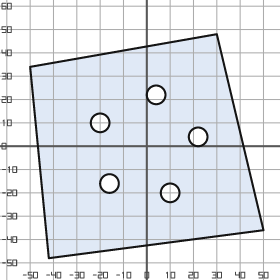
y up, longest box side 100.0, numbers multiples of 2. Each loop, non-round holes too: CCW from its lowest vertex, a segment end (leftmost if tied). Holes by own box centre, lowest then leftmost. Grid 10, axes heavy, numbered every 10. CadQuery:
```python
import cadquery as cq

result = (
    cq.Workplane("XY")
    .moveTo(-42.0, -48.0)
    .lineTo(50.0, -36.0)
    .lineTo(30.0, 48.0)
    .lineTo(-50.0, 34.0)
    .close()
    .moveTo(10.0, -20.0)
    .circle(4.0)
    .moveTo(-16.0, -16.0)
    .circle(4.0)
    .moveTo(22.0, 4.0)
    .circle(4.0)
    .moveTo(-20.0, 10.0)
    .circle(4.0)
    .moveTo(4.0, 22.0)
    .circle(4.0)
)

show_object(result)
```